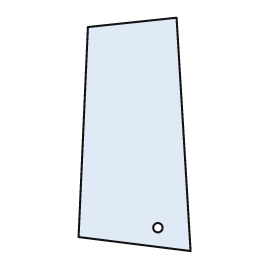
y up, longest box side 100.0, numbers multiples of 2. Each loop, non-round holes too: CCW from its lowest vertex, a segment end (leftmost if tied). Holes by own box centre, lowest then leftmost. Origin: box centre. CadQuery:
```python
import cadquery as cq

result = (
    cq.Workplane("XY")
    .moveTo(24.0, -50.0)
    .lineTo(18.0, 50.0)
    .lineTo(-20.0, 46.0)
    .lineTo(-24.0, -44.0)
    .close()
    .moveTo(10.0, -40.0)
    .circle(2.0)
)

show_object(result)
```